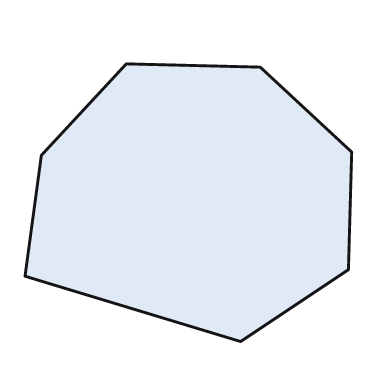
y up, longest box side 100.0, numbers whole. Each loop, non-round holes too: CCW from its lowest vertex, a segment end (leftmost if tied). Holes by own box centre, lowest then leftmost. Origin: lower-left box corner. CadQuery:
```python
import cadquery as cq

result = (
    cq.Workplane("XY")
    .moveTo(66.0, 0.0)
    .lineTo(99.0, 22.0)
    .lineTo(100.0, 58.0)
    .lineTo(72.0, 84.0)
    .lineTo(31.0, 85.0)
    .lineTo(5.0, 57.0)
    .lineTo(0.0, 20.0)
    .close()
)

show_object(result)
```